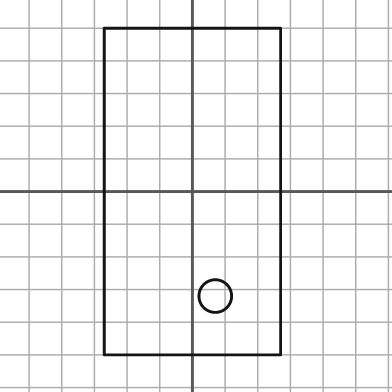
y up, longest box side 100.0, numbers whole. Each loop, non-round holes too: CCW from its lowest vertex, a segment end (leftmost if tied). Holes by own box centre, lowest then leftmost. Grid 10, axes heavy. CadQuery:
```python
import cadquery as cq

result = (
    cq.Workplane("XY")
    .moveTo(-27.0, -50.0)
    .lineTo(27.0, -50.0)
    .lineTo(27.0, 50.0)
    .lineTo(-27.0, 50.0)
    .close()
    .moveTo(7.0, -32.0)
    .circle(5.0)
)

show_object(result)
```